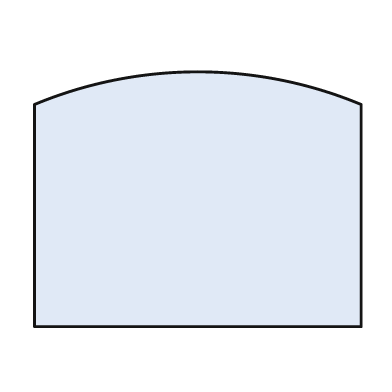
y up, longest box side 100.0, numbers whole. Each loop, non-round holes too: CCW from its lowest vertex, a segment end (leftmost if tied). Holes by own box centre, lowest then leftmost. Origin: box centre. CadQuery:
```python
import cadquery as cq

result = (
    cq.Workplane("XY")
    .moveTo(-50.0, -39.0)
    .lineTo(50.0, -39.0)
    .lineTo(50.0, 29.0)
    .threePointArc((0.0, 39.0), (-50.0, 29.0))
    .close()
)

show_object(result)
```